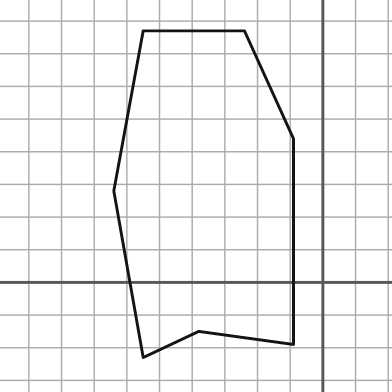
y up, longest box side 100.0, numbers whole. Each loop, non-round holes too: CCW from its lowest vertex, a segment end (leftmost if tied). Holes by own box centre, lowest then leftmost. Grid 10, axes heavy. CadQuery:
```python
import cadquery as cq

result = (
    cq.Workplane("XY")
    .moveTo(-55.0, -23.0)
    .lineTo(-38.0, -15.0)
    .lineTo(-9.0, -19.0)
    .lineTo(-9.0, 44.0)
    .lineTo(-24.0, 77.0)
    .lineTo(-55.0, 77.0)
    .lineTo(-64.0, 28.0)
    .close()
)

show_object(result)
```